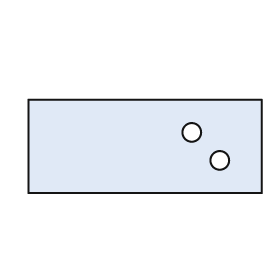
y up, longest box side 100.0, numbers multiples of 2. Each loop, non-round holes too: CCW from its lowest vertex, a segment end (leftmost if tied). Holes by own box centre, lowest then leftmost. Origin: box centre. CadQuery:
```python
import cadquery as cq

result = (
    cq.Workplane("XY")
    .moveTo(-50.0, -20.0)
    .lineTo(50.0, -20.0)
    .lineTo(50.0, 20.0)
    .lineTo(-50.0, 20.0)
    .close()
    .moveTo(32.0, -6.0)
    .circle(4.0)
    .moveTo(20.0, 6.0)
    .circle(4.0)
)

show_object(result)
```